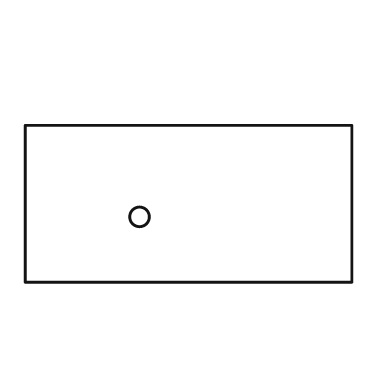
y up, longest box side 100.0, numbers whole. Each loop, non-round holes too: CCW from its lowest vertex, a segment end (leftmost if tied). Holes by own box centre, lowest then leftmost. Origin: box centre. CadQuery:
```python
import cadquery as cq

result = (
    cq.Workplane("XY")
    .moveTo(-50.0, -24.0)
    .lineTo(50.0, -24.0)
    .lineTo(50.0, 24.0)
    .lineTo(-50.0, 24.0)
    .close()
    .moveTo(-15.0, -4.0)
    .circle(3.0)
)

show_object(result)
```